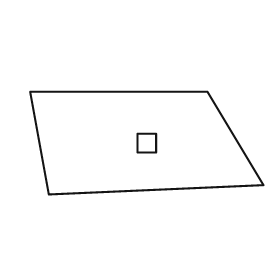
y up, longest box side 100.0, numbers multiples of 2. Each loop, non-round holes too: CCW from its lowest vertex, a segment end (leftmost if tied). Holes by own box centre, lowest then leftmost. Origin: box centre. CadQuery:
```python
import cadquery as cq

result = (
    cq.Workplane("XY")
    .moveTo(-42.0, -22.0)
    .lineTo(50.0, -18.0)
    .lineTo(26.0, 22.0)
    .lineTo(-50.0, 22.0)
    .close()
    .moveTo(-4.0, -4.0)
    .lineTo(4.0, -4.0)
    .lineTo(4.0, 4.0)
    .lineTo(-4.0, 4.0)
    .close()
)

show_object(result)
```